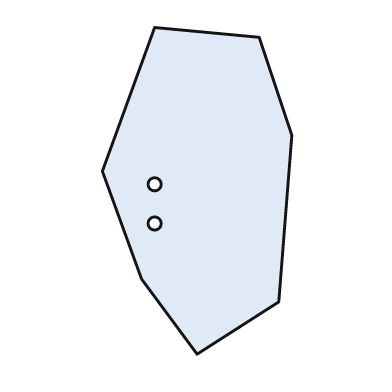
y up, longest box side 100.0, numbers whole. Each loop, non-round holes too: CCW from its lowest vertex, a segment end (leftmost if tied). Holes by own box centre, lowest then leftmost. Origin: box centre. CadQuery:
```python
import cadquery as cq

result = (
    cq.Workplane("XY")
    .moveTo(0.0, -50.0)
    .lineTo(25.0, -34.0)
    .lineTo(29.0, 17.0)
    .lineTo(19.0, 47.0)
    .lineTo(-13.0, 50.0)
    .lineTo(-29.0, 6.0)
    .lineTo(-17.0, -27.0)
    .close()
    .moveTo(-13.0, -10.0)
    .circle(2.0)
    .moveTo(-13.0, 2.0)
    .circle(2.0)
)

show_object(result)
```